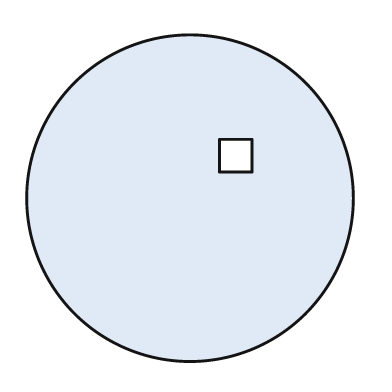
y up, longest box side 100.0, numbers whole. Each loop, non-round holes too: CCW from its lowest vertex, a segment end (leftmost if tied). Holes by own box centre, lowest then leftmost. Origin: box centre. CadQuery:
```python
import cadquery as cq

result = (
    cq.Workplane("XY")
    .moveTo(0.0, 0.0)
    .circle(50.0)
    .moveTo(9.0, 8.0)
    .lineTo(19.0, 8.0)
    .lineTo(19.0, 18.0)
    .lineTo(9.0, 18.0)
    .close()
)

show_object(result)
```